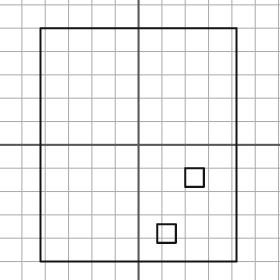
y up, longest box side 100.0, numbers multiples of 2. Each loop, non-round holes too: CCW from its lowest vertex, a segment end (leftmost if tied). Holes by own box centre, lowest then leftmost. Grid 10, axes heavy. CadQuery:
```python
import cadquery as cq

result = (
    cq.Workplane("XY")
    .moveTo(-42.0, -50.0)
    .lineTo(42.0, -50.0)
    .lineTo(42.0, 50.0)
    .lineTo(-42.0, 50.0)
    .close()
    .moveTo(8.0, -42.0)
    .lineTo(16.0, -42.0)
    .lineTo(16.0, -34.0)
    .lineTo(8.0, -34.0)
    .close()
    .moveTo(20.0, -18.0)
    .lineTo(28.0, -18.0)
    .lineTo(28.0, -10.0)
    .lineTo(20.0, -10.0)
    .close()
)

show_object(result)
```